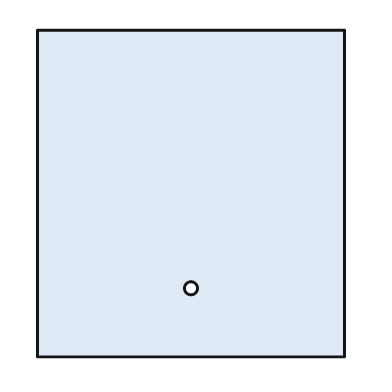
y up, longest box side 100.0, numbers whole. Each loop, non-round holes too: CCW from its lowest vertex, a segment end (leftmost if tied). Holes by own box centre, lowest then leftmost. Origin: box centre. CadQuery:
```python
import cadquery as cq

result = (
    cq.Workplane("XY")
    .moveTo(-47.0, -50.0)
    .lineTo(47.0, -50.0)
    .lineTo(47.0, 50.0)
    .lineTo(-47.0, 50.0)
    .close()
    .moveTo(0.0, -29.0)
    .circle(2.0)
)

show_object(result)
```